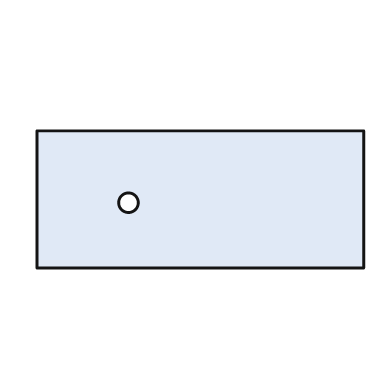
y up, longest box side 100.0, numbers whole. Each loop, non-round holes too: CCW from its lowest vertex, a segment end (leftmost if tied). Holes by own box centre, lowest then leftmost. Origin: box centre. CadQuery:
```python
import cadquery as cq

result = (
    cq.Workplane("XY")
    .moveTo(-50.0, -21.0)
    .lineTo(50.0, -21.0)
    .lineTo(50.0, 21.0)
    .lineTo(-50.0, 21.0)
    .close()
    .moveTo(-22.0, -1.0)
    .circle(3.0)
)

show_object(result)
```